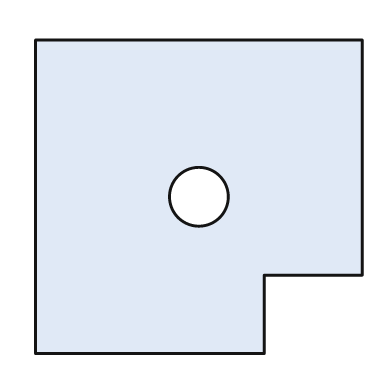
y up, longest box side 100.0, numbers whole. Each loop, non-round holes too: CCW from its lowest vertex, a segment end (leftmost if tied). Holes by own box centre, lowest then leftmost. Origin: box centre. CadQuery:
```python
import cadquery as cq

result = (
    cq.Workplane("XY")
    .moveTo(-50.0, -48.0)
    .lineTo(20.0, -48.0)
    .lineTo(20.0, -24.0)
    .lineTo(50.0, -24.0)
    .lineTo(50.0, 48.0)
    .lineTo(-50.0, 48.0)
    .close()
    .moveTo(0.0, 0.0)
    .circle(9.0)
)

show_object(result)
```